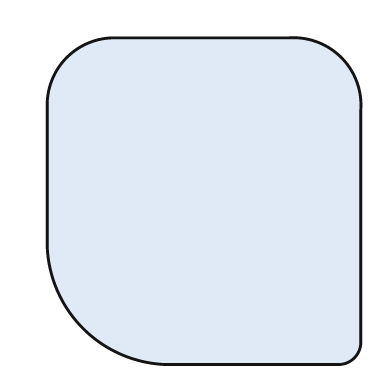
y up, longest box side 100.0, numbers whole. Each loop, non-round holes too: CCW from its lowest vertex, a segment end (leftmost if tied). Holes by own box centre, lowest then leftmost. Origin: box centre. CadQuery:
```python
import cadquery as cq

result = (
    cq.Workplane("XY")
    .moveTo(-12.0, -50.0)
    .lineTo(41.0, -50.0)
    .threePointArc((46.0, -48.0), (48.0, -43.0))
    .lineTo(48.0, 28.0)
    .threePointArc((42.0, 44.0), (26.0, 50.0))
    .lineTo(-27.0, 50.0)
    .threePointArc((-42.0, 44.0), (-48.0, 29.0))
    .lineTo(-48.0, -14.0)
    .threePointArc((-37.0, -39.0), (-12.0, -50.0))
    .close()
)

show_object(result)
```